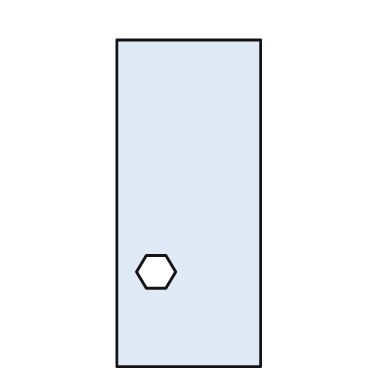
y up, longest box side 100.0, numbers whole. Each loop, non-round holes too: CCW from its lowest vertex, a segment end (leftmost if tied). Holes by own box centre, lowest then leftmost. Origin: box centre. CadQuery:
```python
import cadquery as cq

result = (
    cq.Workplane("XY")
    .moveTo(-22.0, -50.0)
    .lineTo(22.0, -50.0)
    .lineTo(22.0, 50.0)
    .lineTo(-22.0, 50.0)
    .close()
    .moveTo(-13.0, -26.0)
    .lineTo(-7.0, -26.0)
    .lineTo(-4.0, -21.0)
    .lineTo(-7.0, -16.0)
    .lineTo(-13.0, -16.0)
    .lineTo(-16.0, -21.0)
    .close()
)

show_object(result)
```